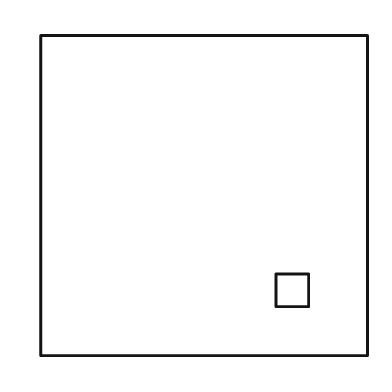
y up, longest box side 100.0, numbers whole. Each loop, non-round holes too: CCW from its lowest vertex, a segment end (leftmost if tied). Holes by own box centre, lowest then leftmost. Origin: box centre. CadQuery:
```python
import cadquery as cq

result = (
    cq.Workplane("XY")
    .moveTo(-50.0, -49.0)
    .lineTo(50.0, -49.0)
    .lineTo(50.0, 49.0)
    .lineTo(-50.0, 49.0)
    .close()
    .moveTo(22.0, -34.0)
    .lineTo(32.0, -34.0)
    .lineTo(32.0, -24.0)
    .lineTo(22.0, -24.0)
    .close()
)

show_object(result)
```